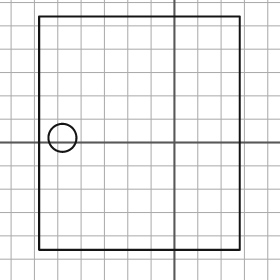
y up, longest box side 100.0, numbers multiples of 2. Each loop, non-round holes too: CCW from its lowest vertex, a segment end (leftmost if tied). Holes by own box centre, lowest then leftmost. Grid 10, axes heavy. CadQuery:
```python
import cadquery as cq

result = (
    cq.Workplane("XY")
    .moveTo(-58.0, -46.0)
    .lineTo(28.0, -46.0)
    .lineTo(28.0, 54.0)
    .lineTo(-58.0, 54.0)
    .close()
    .moveTo(-48.0, 2.0)
    .circle(6.0)
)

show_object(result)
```